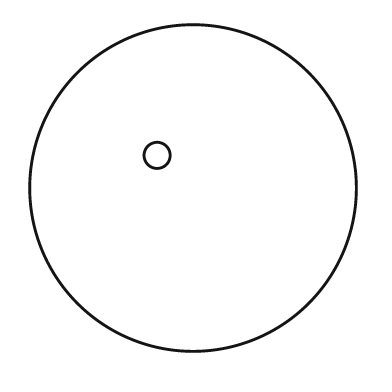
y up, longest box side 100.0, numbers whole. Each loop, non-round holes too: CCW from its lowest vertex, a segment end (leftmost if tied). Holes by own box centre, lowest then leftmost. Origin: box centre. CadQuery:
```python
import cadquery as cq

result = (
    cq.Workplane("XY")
    .moveTo(0.0, 0.0)
    .circle(50.0)
    .moveTo(-11.0, 10.0)
    .circle(4.0)
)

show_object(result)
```